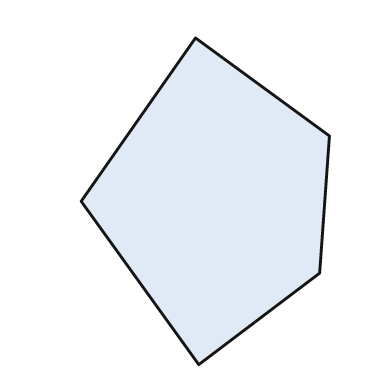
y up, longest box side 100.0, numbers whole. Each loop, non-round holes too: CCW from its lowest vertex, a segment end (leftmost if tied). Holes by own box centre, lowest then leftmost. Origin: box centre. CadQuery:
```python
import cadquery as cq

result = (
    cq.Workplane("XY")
    .moveTo(-2.0, -50.0)
    .lineTo(35.0, -22.0)
    .lineTo(38.0, 20.0)
    .lineTo(-3.0, 50.0)
    .lineTo(-38.0, 0.0)
    .close()
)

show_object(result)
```